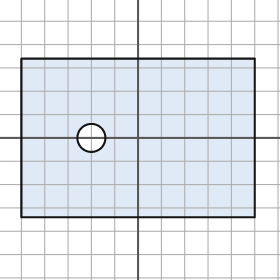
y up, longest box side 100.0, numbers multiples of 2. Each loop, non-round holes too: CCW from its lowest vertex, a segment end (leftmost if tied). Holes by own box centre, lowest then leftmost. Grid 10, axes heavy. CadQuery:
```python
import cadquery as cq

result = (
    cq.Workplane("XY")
    .moveTo(-50.0, -34.0)
    .lineTo(50.0, -34.0)
    .lineTo(50.0, 34.0)
    .lineTo(-50.0, 34.0)
    .close()
    .moveTo(-20.0, 0.0)
    .circle(6.0)
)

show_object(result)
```